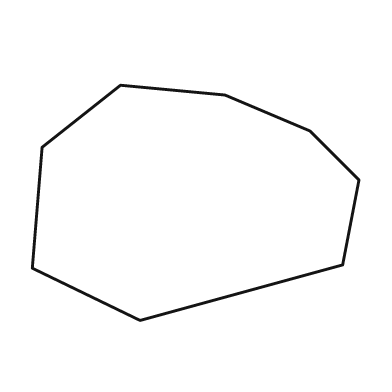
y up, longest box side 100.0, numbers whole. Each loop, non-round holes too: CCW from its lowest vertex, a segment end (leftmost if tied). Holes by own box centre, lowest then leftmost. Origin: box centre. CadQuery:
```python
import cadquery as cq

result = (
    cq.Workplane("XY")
    .moveTo(-17.0, -36.0)
    .lineTo(45.0, -19.0)
    .lineTo(50.0, 7.0)
    .lineTo(35.0, 22.0)
    .lineTo(9.0, 33.0)
    .lineTo(-23.0, 36.0)
    .lineTo(-47.0, 17.0)
    .lineTo(-50.0, -20.0)
    .close()
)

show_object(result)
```